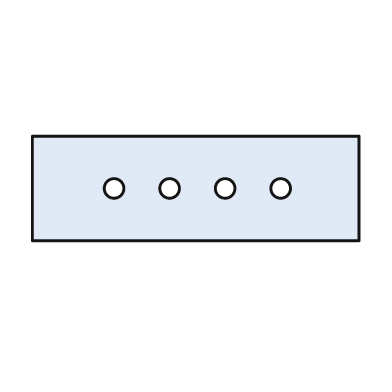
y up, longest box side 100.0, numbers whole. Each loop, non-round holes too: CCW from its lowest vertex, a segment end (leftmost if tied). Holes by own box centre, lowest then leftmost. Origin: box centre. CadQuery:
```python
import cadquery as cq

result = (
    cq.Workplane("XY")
    .moveTo(-50.0, -16.0)
    .lineTo(50.0, -16.0)
    .lineTo(50.0, 16.0)
    .lineTo(-50.0, 16.0)
    .close()
    .moveTo(-25.0, 0.0)
    .circle(3.0)
    .moveTo(-8.0, 0.0)
    .circle(3.0)
    .moveTo(9.0, 0.0)
    .circle(3.0)
    .moveTo(26.0, 0.0)
    .circle(3.0)
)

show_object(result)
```